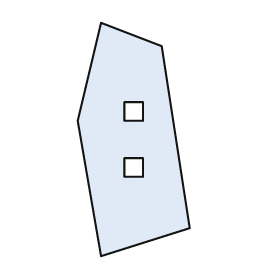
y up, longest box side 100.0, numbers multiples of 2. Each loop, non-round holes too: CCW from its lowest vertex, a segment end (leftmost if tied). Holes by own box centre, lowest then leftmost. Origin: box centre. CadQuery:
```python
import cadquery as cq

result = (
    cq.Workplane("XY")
    .moveTo(-14.0, -50.0)
    .lineTo(24.0, -38.0)
    .lineTo(12.0, 40.0)
    .lineTo(-14.0, 50.0)
    .lineTo(-24.0, 8.0)
    .close()
    .moveTo(-4.0, -16.0)
    .lineTo(4.0, -16.0)
    .lineTo(4.0, -8.0)
    .lineTo(-4.0, -8.0)
    .close()
    .moveTo(-4.0, 8.0)
    .lineTo(4.0, 8.0)
    .lineTo(4.0, 16.0)
    .lineTo(-4.0, 16.0)
    .close()
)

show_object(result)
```